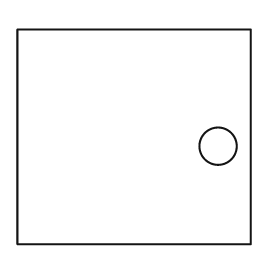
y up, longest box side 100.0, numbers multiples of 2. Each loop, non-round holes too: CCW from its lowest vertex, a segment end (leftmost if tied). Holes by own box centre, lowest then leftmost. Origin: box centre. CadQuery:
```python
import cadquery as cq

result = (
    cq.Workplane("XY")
    .moveTo(-50.0, -46.0)
    .lineTo(50.0, -46.0)
    .lineTo(50.0, 46.0)
    .lineTo(-50.0, 46.0)
    .close()
    .moveTo(36.0, -4.0)
    .circle(8.0)
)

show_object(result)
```